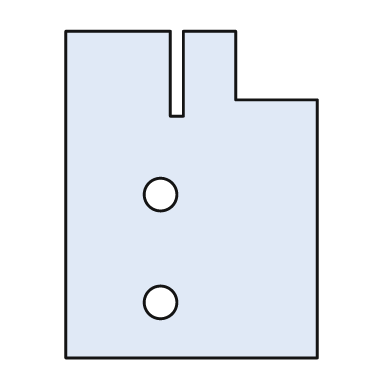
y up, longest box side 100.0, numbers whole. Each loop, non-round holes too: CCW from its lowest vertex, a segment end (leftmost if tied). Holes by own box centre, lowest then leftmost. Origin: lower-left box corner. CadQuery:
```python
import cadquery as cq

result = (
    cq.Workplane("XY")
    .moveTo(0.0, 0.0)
    .lineTo(77.0, 0.0)
    .lineTo(77.0, 79.0)
    .lineTo(52.0, 79.0)
    .lineTo(52.0, 100.0)
    .lineTo(36.0, 100.0)
    .lineTo(36.0, 74.0)
    .lineTo(32.0, 74.0)
    .lineTo(32.0, 100.0)
    .lineTo(0.0, 100.0)
    .close()
    .moveTo(29.0, 17.0)
    .circle(5.0)
    .moveTo(29.0, 50.0)
    .circle(5.0)
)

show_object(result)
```